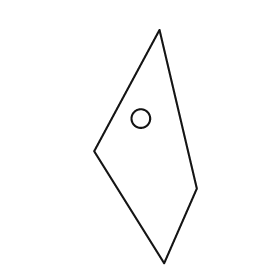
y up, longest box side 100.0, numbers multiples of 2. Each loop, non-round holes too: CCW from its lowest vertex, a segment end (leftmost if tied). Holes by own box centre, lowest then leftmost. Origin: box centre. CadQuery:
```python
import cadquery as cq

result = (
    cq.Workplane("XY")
    .moveTo(8.0, -50.0)
    .lineTo(22.0, -18.0)
    .lineTo(6.0, 50.0)
    .lineTo(-22.0, -2.0)
    .close()
    .moveTo(-2.0, 12.0)
    .circle(4.0)
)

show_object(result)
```